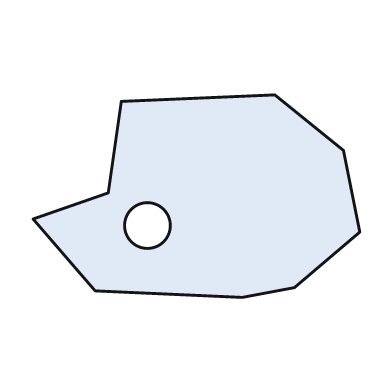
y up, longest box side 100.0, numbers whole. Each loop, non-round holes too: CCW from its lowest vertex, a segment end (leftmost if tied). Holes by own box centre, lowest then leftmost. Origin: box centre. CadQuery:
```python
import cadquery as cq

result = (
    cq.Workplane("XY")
    .moveTo(14.0, -31.0)
    .lineTo(30.0, -28.0)
    .lineTo(50.0, -11.0)
    .lineTo(45.0, 14.0)
    .lineTo(24.0, 31.0)
    .lineTo(-23.0, 29.0)
    .lineTo(-27.0, 1.0)
    .lineTo(-50.0, -7.0)
    .lineTo(-31.0, -29.0)
    .close()
    .moveTo(-15.0, -9.0)
    .circle(7.0)
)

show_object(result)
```